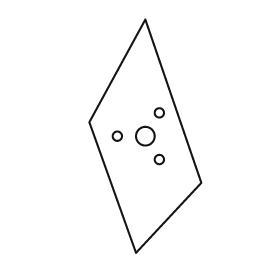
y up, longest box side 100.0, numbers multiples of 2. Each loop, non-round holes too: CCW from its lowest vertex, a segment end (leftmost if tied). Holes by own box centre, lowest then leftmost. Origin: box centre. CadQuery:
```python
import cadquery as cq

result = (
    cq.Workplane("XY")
    .moveTo(-4.0, -50.0)
    .lineTo(24.0, -20.0)
    .lineTo(0.0, 50.0)
    .lineTo(-24.0, 6.0)
    .close()
    .moveTo(6.0, -10.0)
    .circle(2.0)
    .moveTo(-12.0, 0.0)
    .circle(2.0)
    .moveTo(0.0, 0.0)
    .circle(4.0)
    .moveTo(6.0, 10.0)
    .circle(2.0)
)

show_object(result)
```